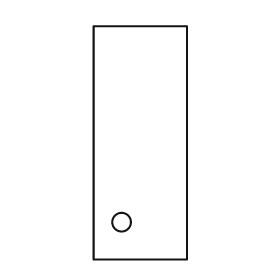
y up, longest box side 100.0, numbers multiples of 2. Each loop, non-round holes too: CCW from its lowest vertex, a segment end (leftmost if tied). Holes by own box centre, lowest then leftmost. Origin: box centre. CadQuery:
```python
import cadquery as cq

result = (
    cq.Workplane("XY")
    .moveTo(-20.0, -50.0)
    .lineTo(20.0, -50.0)
    .lineTo(20.0, 50.0)
    .lineTo(-20.0, 50.0)
    .close()
    .moveTo(-8.0, -34.0)
    .circle(4.0)
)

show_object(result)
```